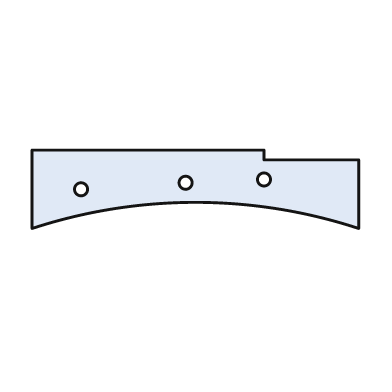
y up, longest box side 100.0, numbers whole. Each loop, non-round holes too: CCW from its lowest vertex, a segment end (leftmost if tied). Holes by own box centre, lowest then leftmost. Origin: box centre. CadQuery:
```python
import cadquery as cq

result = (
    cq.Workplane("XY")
    .moveTo(-50.0, -12.0)
    .threePointArc((0.0, -4.0), (50.0, -12.0))
    .lineTo(50.0, 9.0)
    .lineTo(21.0, 9.0)
    .lineTo(21.0, 12.0)
    .lineTo(-50.0, 12.0)
    .close()
    .moveTo(-35.0, 0.0)
    .circle(2.0)
    .moveTo(-3.0, 2.0)
    .circle(2.0)
    .moveTo(21.0, 3.0)
    .circle(2.0)
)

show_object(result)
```